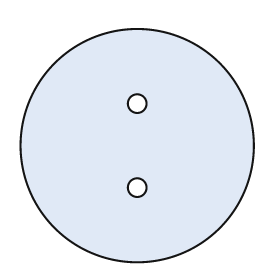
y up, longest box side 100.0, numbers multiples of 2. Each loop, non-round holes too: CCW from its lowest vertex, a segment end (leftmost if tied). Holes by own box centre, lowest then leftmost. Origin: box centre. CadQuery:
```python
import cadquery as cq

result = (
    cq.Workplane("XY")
    .moveTo(0.0, 0.0)
    .circle(50.0)
    .moveTo(0.0, -18.0)
    .circle(4.0)
    .moveTo(0.0, 18.0)
    .circle(4.0)
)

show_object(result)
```